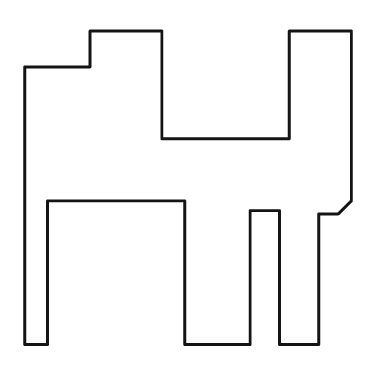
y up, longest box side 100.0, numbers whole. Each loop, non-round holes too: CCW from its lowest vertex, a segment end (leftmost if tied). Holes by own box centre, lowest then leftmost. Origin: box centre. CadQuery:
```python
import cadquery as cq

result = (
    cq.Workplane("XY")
    .moveTo(-50.0, -48.0)
    .lineTo(-43.0, -48.0)
    .lineTo(-43.0, -4.0)
    .lineTo(-1.0, -4.0)
    .lineTo(-1.0, -48.0)
    .lineTo(19.0, -48.0)
    .lineTo(19.0, -7.0)
    .lineTo(28.0, -7.0)
    .lineTo(28.0, -48.0)
    .lineTo(40.0, -48.0)
    .lineTo(40.0, -8.0)
    .lineTo(46.0, -8.0)
    .lineTo(50.0, -4.0)
    .lineTo(50.0, 48.0)
    .lineTo(31.0, 48.0)
    .lineTo(31.0, 15.0)
    .lineTo(-8.0, 15.0)
    .lineTo(-8.0, 48.0)
    .lineTo(-30.0, 48.0)
    .lineTo(-30.0, 37.0)
    .lineTo(-50.0, 37.0)
    .close()
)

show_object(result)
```